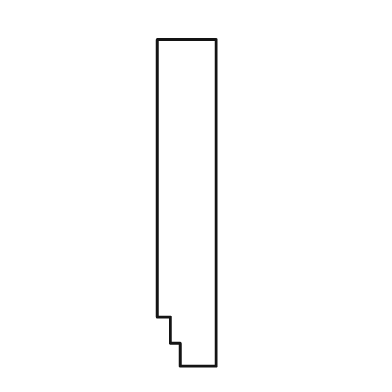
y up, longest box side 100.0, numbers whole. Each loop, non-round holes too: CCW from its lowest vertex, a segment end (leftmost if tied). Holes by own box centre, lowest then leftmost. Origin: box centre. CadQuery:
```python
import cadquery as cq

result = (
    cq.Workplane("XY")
    .moveTo(-2.0, -50.0)
    .lineTo(9.0, -50.0)
    .lineTo(9.0, 50.0)
    .lineTo(-9.0, 50.0)
    .lineTo(-9.0, -35.0)
    .lineTo(-5.0, -35.0)
    .lineTo(-5.0, -43.0)
    .lineTo(-2.0, -43.0)
    .close()
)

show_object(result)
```